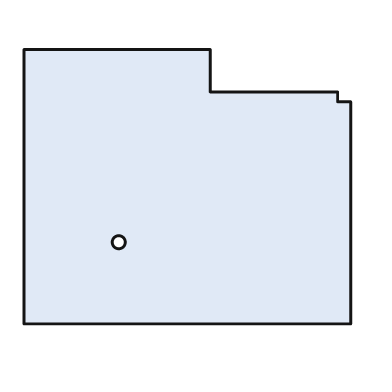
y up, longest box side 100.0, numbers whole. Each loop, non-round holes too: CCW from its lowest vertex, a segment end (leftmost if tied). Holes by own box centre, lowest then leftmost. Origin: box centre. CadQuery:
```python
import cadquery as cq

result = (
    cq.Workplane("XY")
    .moveTo(-50.0, -42.0)
    .lineTo(50.0, -42.0)
    .lineTo(50.0, 26.0)
    .lineTo(46.0, 26.0)
    .lineTo(46.0, 29.0)
    .lineTo(7.0, 29.0)
    .lineTo(7.0, 42.0)
    .lineTo(-50.0, 42.0)
    .close()
    .moveTo(-21.0, -17.0)
    .circle(2.0)
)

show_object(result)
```